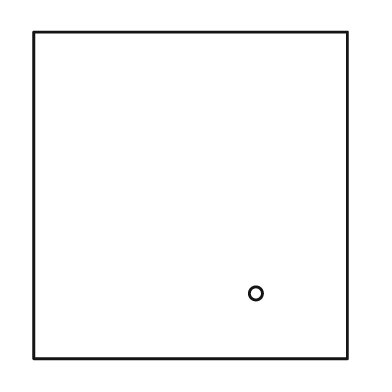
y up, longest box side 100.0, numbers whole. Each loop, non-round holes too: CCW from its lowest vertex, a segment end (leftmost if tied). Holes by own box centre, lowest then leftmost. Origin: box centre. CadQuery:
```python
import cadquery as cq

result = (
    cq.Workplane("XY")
    .moveTo(-48.0, -50.0)
    .lineTo(48.0, -50.0)
    .lineTo(48.0, 50.0)
    .lineTo(-48.0, 50.0)
    .close()
    .moveTo(20.0, -30.0)
    .circle(2.0)
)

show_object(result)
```